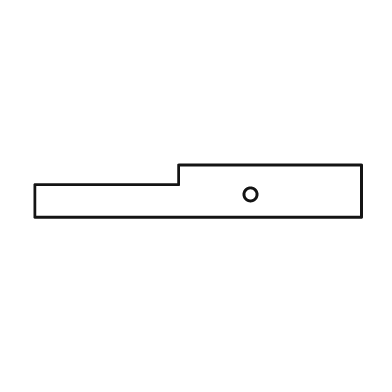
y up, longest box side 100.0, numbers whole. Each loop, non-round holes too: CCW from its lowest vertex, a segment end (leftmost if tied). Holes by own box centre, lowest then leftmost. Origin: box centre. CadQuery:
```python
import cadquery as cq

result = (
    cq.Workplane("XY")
    .moveTo(-50.0, -8.0)
    .lineTo(50.0, -8.0)
    .lineTo(50.0, 8.0)
    .lineTo(-6.0, 8.0)
    .lineTo(-6.0, 2.0)
    .lineTo(-50.0, 2.0)
    .close()
    .moveTo(16.0, -1.0)
    .circle(2.0)
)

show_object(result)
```